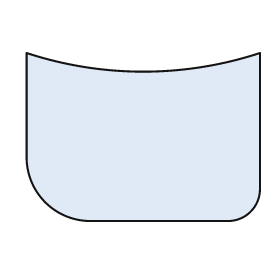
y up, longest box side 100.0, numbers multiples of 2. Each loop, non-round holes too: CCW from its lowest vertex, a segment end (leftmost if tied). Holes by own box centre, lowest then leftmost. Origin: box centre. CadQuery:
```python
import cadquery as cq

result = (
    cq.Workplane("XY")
    .moveTo(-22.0, -36.0)
    .lineTo(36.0, -36.0)
    .threePointArc((46.0, -32.0), (50.0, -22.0))
    .lineTo(50.0, 36.0)
    .threePointArc((0.0, 28.0), (-50.0, 36.0))
    .lineTo(-50.0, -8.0)
    .threePointArc((-42.0, -28.0), (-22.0, -36.0))
    .close()
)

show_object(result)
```